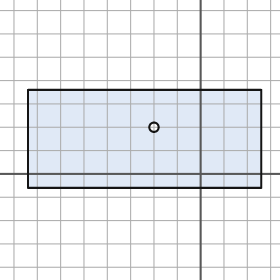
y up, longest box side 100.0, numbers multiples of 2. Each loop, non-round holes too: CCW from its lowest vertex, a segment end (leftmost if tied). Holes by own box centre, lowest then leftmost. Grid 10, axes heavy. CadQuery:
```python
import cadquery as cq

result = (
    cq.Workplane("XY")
    .moveTo(-74.0, -6.0)
    .lineTo(26.0, -6.0)
    .lineTo(26.0, 36.0)
    .lineTo(-74.0, 36.0)
    .close()
    .moveTo(-20.0, 20.0)
    .circle(2.0)
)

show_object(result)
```